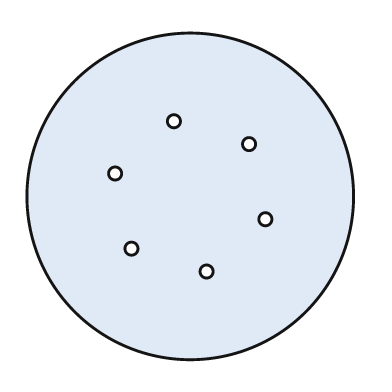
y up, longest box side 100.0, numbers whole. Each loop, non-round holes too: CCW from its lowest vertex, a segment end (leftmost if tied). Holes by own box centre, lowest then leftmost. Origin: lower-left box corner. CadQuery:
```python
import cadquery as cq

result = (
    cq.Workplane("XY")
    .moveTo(50.0, 50.0)
    .circle(50.0)
    .moveTo(55.0, 27.0)
    .circle(2.0)
    .moveTo(32.0, 34.0)
    .circle(2.0)
    .moveTo(73.0, 43.0)
    .circle(2.0)
    .moveTo(27.0, 57.0)
    .circle(2.0)
    .moveTo(68.0, 66.0)
    .circle(2.0)
    .moveTo(45.0, 73.0)
    .circle(2.0)
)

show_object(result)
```